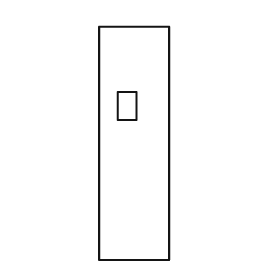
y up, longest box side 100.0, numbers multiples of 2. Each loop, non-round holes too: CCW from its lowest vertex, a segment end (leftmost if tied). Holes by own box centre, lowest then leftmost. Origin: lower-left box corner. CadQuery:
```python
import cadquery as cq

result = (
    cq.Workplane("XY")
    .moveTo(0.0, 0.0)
    .lineTo(30.0, 0.0)
    .lineTo(30.0, 100.0)
    .lineTo(0.0, 100.0)
    .close()
    .moveTo(8.0, 60.0)
    .lineTo(16.0, 60.0)
    .lineTo(16.0, 72.0)
    .lineTo(8.0, 72.0)
    .close()
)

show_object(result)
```